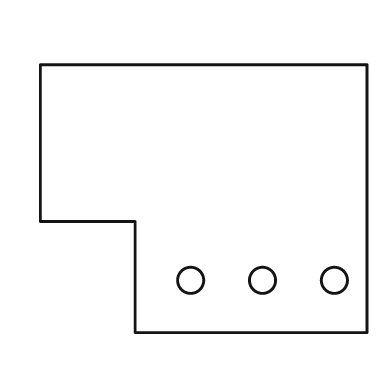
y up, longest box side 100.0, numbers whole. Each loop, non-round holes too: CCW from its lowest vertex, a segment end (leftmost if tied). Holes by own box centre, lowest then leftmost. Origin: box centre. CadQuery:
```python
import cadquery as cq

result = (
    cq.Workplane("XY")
    .moveTo(-21.0, -41.0)
    .lineTo(50.0, -41.0)
    .lineTo(50.0, 41.0)
    .lineTo(-50.0, 41.0)
    .lineTo(-50.0, -7.0)
    .lineTo(-21.0, -7.0)
    .close()
    .moveTo(-4.0, -25.0)
    .circle(4.0)
    .moveTo(18.0, -25.0)
    .circle(4.0)
    .moveTo(40.0, -25.0)
    .circle(4.0)
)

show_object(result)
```